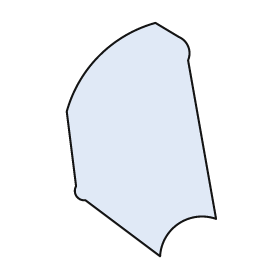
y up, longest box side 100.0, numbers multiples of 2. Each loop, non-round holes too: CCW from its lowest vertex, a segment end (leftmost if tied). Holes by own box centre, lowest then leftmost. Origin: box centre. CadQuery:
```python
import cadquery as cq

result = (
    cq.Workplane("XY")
    .moveTo(8.0, -50.0)
    .threePointArc((16.0, -36.0), (32.0, -34.0))
    .lineTo(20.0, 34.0)
    .threePointArc((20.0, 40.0), (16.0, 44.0))
    .lineTo(6.0, 50.0)
    .threePointArc((-18.0, 36.0), (-32.0, 12.0))
    .lineTo(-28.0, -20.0)
    .threePointArc((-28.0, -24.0), (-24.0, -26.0))
    .close()
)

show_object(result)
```